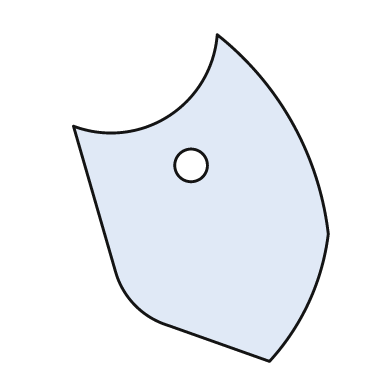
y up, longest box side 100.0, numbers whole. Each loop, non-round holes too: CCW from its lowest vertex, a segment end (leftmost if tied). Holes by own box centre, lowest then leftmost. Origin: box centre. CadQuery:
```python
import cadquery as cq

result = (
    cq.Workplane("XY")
    .moveTo(21.0, -50.0)
    .threePointArc((33.0, -32.0), (39.0, -11.0))
    .threePointArc((28.0, 23.0), (5.0, 50.0))
    .threePointArc((-10.0, 25.0), (-39.0, 22.0))
    .lineTo(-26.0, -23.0)
    .threePointArc((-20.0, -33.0), (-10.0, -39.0))
    .close()
    .moveTo(-3.0, 10.0)
    .circle(5.0)
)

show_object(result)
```